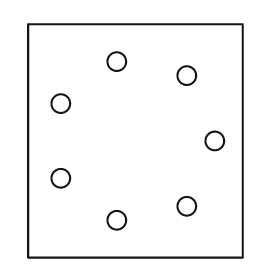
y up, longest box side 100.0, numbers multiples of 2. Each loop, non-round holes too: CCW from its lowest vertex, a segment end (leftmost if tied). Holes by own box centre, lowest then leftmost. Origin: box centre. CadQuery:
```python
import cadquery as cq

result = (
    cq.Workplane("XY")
    .moveTo(-46.0, -50.0)
    .lineTo(46.0, -50.0)
    .lineTo(46.0, 50.0)
    .lineTo(-46.0, 50.0)
    .close()
    .moveTo(-8.0, -34.0)
    .circle(4.0)
    .moveTo(22.0, -28.0)
    .circle(4.0)
    .moveTo(-32.0, -16.0)
    .circle(4.0)
    .moveTo(34.0, 0.0)
    .circle(4.0)
    .moveTo(-32.0, 16.0)
    .circle(4.0)
    .moveTo(22.0, 28.0)
    .circle(4.0)
    .moveTo(-8.0, 34.0)
    .circle(4.0)
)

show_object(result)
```